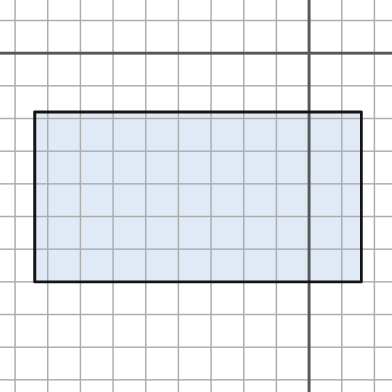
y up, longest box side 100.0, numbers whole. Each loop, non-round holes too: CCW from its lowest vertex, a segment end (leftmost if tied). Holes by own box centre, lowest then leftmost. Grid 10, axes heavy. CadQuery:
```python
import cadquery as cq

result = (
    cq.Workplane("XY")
    .moveTo(-84.0, -70.0)
    .lineTo(16.0, -70.0)
    .lineTo(16.0, -18.0)
    .lineTo(-84.0, -18.0)
    .close()
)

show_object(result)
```